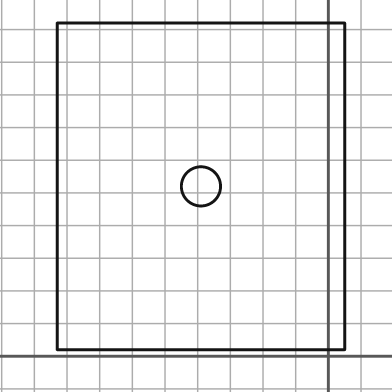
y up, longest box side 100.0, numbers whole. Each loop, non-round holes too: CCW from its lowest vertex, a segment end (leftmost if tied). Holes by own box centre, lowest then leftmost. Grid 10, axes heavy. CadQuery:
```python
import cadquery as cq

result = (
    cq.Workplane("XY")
    .moveTo(-83.0, 2.0)
    .lineTo(5.0, 2.0)
    .lineTo(5.0, 102.0)
    .lineTo(-83.0, 102.0)
    .close()
    .moveTo(-39.0, 52.0)
    .circle(6.0)
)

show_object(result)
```